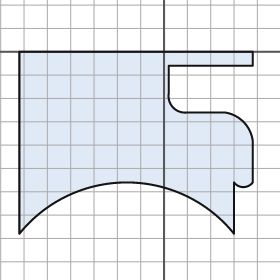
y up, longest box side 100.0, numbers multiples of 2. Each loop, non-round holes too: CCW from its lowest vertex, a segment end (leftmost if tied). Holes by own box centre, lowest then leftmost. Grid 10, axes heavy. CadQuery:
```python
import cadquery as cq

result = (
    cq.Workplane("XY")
    .moveTo(-62.0, -78.0)
    .threePointArc((-16.0, -56.0), (30.0, -78.0))
    .lineTo(30.0, -56.0)
    .threePointArc((34.0, -58.0), (38.0, -56.0))
    .lineTo(38.0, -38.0)
    .threePointArc((34.0, -30.0), (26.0, -26.0))
    .lineTo(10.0, -26.0)
    .threePointArc((4.0, -24.0), (2.0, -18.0))
    .lineTo(2.0, -6.0)
    .lineTo(38.0, -6.0)
    .lineTo(38.0, 0.0)
    .lineTo(-62.0, 0.0)
    .close()
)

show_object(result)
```